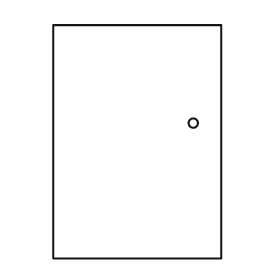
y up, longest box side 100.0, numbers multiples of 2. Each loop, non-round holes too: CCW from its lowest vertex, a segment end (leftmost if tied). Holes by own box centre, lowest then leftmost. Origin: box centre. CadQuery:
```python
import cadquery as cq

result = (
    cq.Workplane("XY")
    .moveTo(-36.0, -50.0)
    .lineTo(36.0, -50.0)
    .lineTo(36.0, 50.0)
    .lineTo(-36.0, 50.0)
    .close()
    .moveTo(24.0, 8.0)
    .circle(2.0)
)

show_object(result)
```